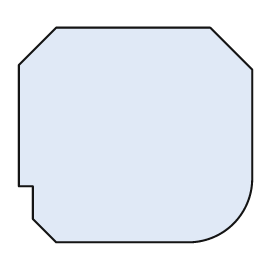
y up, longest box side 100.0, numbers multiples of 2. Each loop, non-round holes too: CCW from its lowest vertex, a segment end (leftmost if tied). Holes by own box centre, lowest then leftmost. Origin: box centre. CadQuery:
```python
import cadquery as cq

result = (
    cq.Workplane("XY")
    .moveTo(-34.0, -46.0)
    .lineTo(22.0, -46.0)
    .threePointArc((42.0, -38.0), (50.0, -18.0))
    .lineTo(50.0, 28.0)
    .lineTo(32.0, 46.0)
    .lineTo(-34.0, 46.0)
    .lineTo(-50.0, 30.0)
    .lineTo(-50.0, -22.0)
    .lineTo(-44.0, -22.0)
    .lineTo(-44.0, -36.0)
    .close()
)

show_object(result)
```